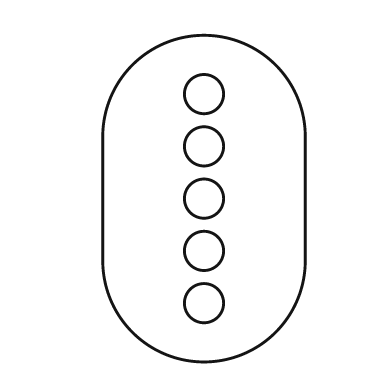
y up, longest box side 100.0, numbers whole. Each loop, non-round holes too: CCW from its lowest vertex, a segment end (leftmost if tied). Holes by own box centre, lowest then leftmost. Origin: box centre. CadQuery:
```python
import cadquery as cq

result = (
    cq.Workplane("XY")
    .moveTo(-31.0, -19.0)
    .threePointArc((0.0, -50.0), (31.0, -19.0))
    .lineTo(31.0, 19.0)
    .threePointArc((0.0, 50.0), (-31.0, 19.0))
    .close()
    .moveTo(0.0, -32.0)
    .circle(6.0)
    .moveTo(0.0, -16.0)
    .circle(6.0)
    .moveTo(0.0, 0.0)
    .circle(6.0)
    .moveTo(0.0, 16.0)
    .circle(6.0)
    .moveTo(0.0, 32.0)
    .circle(6.0)
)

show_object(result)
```